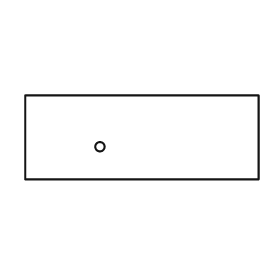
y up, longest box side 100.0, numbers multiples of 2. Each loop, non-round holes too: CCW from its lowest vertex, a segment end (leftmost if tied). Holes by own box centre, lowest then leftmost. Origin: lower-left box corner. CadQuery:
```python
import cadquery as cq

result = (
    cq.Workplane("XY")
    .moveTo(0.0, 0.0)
    .lineTo(100.0, 0.0)
    .lineTo(100.0, 36.0)
    .lineTo(0.0, 36.0)
    .close()
    .moveTo(32.0, 14.0)
    .circle(2.0)
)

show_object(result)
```